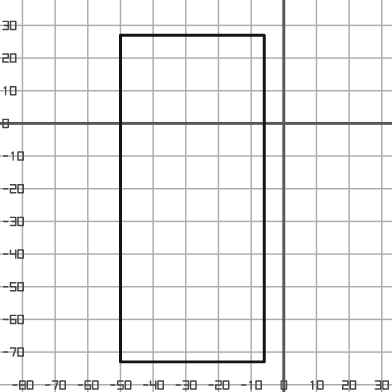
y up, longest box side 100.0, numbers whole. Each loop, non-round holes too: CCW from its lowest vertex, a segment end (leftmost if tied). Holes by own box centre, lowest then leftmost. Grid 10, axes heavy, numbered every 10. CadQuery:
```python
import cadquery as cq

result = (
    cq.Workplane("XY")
    .moveTo(-50.0, -73.0)
    .lineTo(-6.0, -73.0)
    .lineTo(-6.0, 27.0)
    .lineTo(-50.0, 27.0)
    .close()
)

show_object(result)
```